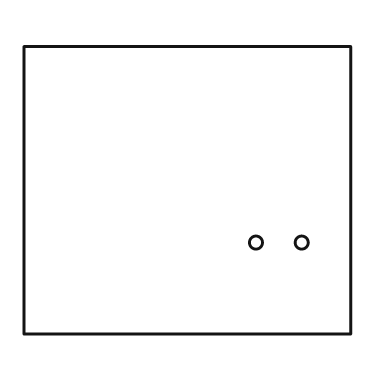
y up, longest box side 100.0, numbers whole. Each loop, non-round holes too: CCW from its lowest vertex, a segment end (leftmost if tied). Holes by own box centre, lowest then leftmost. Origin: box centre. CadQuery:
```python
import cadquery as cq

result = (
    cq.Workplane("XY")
    .moveTo(-50.0, -44.0)
    .lineTo(50.0, -44.0)
    .lineTo(50.0, 44.0)
    .lineTo(-50.0, 44.0)
    .close()
    .moveTo(21.0, -16.0)
    .circle(2.0)
    .moveTo(35.0, -16.0)
    .circle(2.0)
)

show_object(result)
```